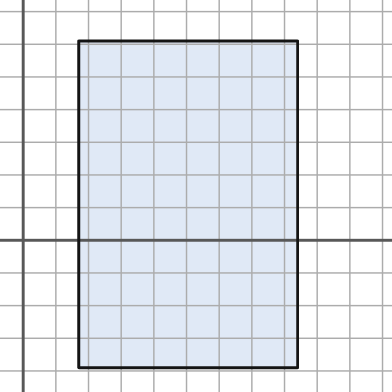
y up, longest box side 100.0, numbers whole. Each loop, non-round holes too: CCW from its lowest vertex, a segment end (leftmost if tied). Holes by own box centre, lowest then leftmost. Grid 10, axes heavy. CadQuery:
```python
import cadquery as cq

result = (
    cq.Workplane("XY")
    .moveTo(17.0, -39.0)
    .lineTo(84.0, -39.0)
    .lineTo(84.0, 61.0)
    .lineTo(17.0, 61.0)
    .close()
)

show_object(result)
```